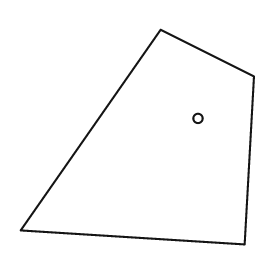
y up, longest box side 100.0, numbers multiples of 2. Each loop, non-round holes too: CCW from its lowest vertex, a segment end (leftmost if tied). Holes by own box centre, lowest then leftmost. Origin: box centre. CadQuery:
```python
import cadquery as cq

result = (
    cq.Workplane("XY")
    .moveTo(46.0, -46.0)
    .lineTo(50.0, 26.0)
    .lineTo(10.0, 46.0)
    .lineTo(-50.0, -40.0)
    .close()
    .moveTo(26.0, 8.0)
    .circle(2.0)
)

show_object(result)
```